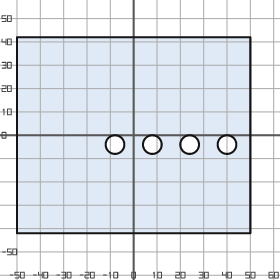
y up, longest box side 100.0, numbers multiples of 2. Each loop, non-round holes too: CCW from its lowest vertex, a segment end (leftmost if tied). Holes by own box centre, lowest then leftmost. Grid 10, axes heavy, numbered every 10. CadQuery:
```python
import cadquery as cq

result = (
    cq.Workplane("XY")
    .moveTo(-50.0, -42.0)
    .lineTo(50.0, -42.0)
    .lineTo(50.0, 42.0)
    .lineTo(-50.0, 42.0)
    .close()
    .moveTo(-8.0, -4.0)
    .circle(4.0)
    .moveTo(8.0, -4.0)
    .circle(4.0)
    .moveTo(24.0, -4.0)
    .circle(4.0)
    .moveTo(40.0, -4.0)
    .circle(4.0)
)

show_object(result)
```